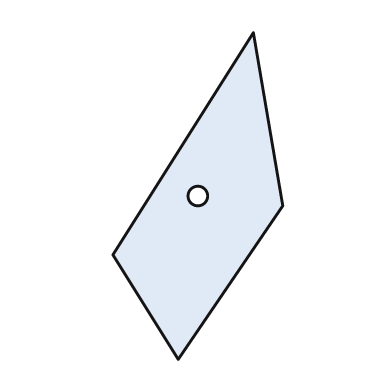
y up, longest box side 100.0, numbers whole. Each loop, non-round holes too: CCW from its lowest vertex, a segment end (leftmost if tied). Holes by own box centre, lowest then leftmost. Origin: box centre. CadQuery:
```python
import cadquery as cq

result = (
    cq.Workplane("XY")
    .moveTo(-6.0, -50.0)
    .lineTo(26.0, -3.0)
    .lineTo(17.0, 50.0)
    .lineTo(-26.0, -18.0)
    .close()
    .moveTo(0.0, 0.0)
    .circle(3.0)
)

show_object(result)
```